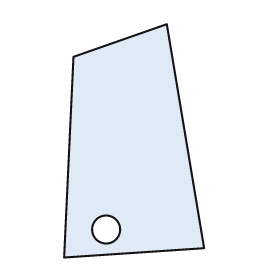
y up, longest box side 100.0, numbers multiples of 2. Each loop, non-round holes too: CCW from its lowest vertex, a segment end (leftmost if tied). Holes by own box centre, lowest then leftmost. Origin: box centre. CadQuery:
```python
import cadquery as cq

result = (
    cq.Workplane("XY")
    .moveTo(-30.0, -50.0)
    .lineTo(30.0, -46.0)
    .lineTo(14.0, 50.0)
    .lineTo(-26.0, 36.0)
    .close()
    .moveTo(-12.0, -38.0)
    .circle(6.0)
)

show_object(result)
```